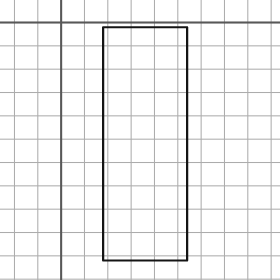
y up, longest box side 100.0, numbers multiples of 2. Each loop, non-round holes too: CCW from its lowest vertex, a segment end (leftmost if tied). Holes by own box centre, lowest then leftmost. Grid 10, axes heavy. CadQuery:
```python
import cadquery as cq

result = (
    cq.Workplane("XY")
    .moveTo(18.0, -102.0)
    .lineTo(54.0, -102.0)
    .lineTo(54.0, -2.0)
    .lineTo(18.0, -2.0)
    .close()
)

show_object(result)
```